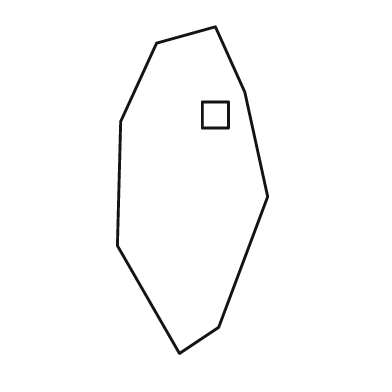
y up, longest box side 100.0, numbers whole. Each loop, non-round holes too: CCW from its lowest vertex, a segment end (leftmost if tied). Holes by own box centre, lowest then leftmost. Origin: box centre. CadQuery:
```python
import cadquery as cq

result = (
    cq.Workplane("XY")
    .moveTo(-4.0, -50.0)
    .lineTo(8.0, -42.0)
    .lineTo(23.0, -2.0)
    .lineTo(16.0, 30.0)
    .lineTo(7.0, 50.0)
    .lineTo(-11.0, 45.0)
    .lineTo(-22.0, 21.0)
    .lineTo(-23.0, -17.0)
    .close()
    .moveTo(3.0, 19.0)
    .lineTo(11.0, 19.0)
    .lineTo(11.0, 27.0)
    .lineTo(3.0, 27.0)
    .close()
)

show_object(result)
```